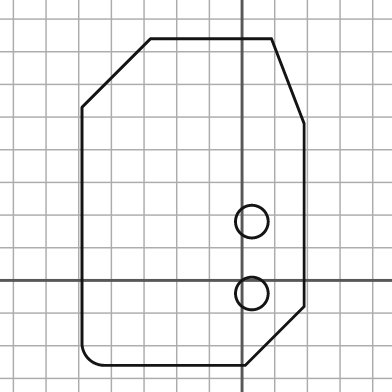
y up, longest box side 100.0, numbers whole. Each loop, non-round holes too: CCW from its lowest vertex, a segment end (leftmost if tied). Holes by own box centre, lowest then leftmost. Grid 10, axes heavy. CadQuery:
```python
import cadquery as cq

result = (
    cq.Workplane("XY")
    .moveTo(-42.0, -26.0)
    .lineTo(1.0, -26.0)
    .lineTo(19.0, -8.0)
    .lineTo(19.0, 48.0)
    .lineTo(9.0, 74.0)
    .lineTo(-28.0, 74.0)
    .lineTo(-49.0, 53.0)
    .lineTo(-49.0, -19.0)
    .threePointArc((-47.0, -24.0), (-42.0, -26.0))
    .close()
    .moveTo(3.0, -4.0)
    .circle(5.0)
    .moveTo(3.0, 18.0)
    .circle(5.0)
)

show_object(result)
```